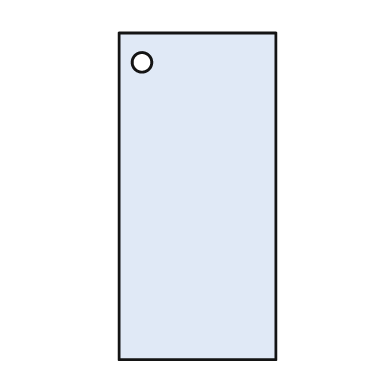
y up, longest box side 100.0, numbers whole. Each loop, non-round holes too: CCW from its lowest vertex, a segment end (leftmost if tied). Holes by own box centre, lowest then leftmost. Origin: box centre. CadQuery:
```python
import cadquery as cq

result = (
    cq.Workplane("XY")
    .moveTo(-24.0, -50.0)
    .lineTo(24.0, -50.0)
    .lineTo(24.0, 50.0)
    .lineTo(-24.0, 50.0)
    .close()
    .moveTo(-17.0, 41.0)
    .circle(3.0)
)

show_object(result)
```